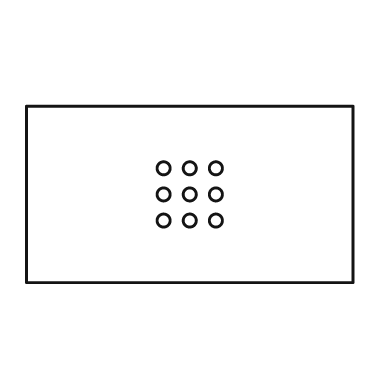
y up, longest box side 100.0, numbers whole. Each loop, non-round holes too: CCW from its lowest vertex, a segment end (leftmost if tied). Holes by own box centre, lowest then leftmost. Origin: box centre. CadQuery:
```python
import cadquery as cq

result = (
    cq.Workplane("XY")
    .moveTo(-50.0, -27.0)
    .lineTo(50.0, -27.0)
    .lineTo(50.0, 27.0)
    .lineTo(-50.0, 27.0)
    .close()
    .moveTo(-8.0, -8.0)
    .circle(2.0)
    .moveTo(0.0, -8.0)
    .circle(2.0)
    .moveTo(8.0, -8.0)
    .circle(2.0)
    .moveTo(-8.0, 0.0)
    .circle(2.0)
    .moveTo(0.0, 0.0)
    .circle(2.0)
    .moveTo(8.0, 0.0)
    .circle(2.0)
    .moveTo(-8.0, 8.0)
    .circle(2.0)
    .moveTo(0.0, 8.0)
    .circle(2.0)
    .moveTo(8.0, 8.0)
    .circle(2.0)
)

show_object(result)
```